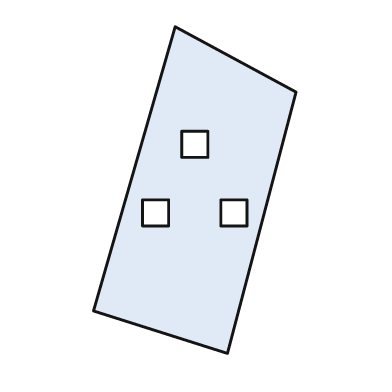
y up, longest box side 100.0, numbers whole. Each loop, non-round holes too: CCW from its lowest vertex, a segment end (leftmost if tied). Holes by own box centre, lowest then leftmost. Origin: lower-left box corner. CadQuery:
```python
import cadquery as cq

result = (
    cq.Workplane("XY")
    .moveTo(41.0, 0.0)
    .lineTo(62.0, 80.0)
    .lineTo(25.0, 100.0)
    .lineTo(0.0, 13.0)
    .close()
    .moveTo(15.0, 39.0)
    .lineTo(23.0, 39.0)
    .lineTo(23.0, 47.0)
    .lineTo(15.0, 47.0)
    .close()
    .moveTo(39.0, 39.0)
    .lineTo(47.0, 39.0)
    .lineTo(47.0, 47.0)
    .lineTo(39.0, 47.0)
    .close()
    .moveTo(27.0, 60.0)
    .lineTo(35.0, 60.0)
    .lineTo(35.0, 68.0)
    .lineTo(27.0, 68.0)
    .close()
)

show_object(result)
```